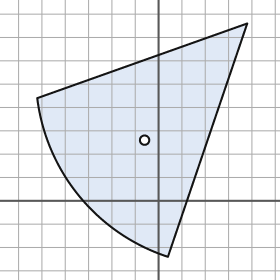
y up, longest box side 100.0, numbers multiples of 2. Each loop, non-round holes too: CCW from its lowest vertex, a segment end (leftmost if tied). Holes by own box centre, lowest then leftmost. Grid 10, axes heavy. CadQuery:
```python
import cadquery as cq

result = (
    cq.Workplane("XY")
    .moveTo(4.0, -24.0)
    .lineTo(38.0, 76.0)
    .lineTo(-52.0, 44.0)
    .threePointArc((-34.0, 2.0), (4.0, -24.0))
    .close()
    .moveTo(-6.0, 26.0)
    .circle(2.0)
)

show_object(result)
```